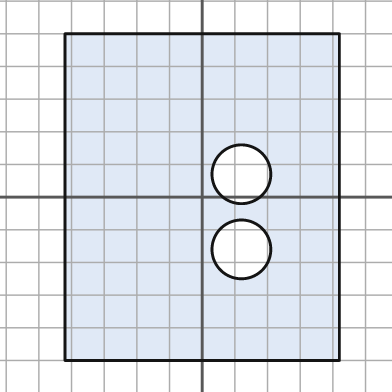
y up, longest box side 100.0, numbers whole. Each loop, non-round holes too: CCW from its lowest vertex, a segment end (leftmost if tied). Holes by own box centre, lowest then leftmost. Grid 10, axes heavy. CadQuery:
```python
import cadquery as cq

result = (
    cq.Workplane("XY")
    .moveTo(-42.0, -50.0)
    .lineTo(42.0, -50.0)
    .lineTo(42.0, 50.0)
    .lineTo(-42.0, 50.0)
    .close()
    .moveTo(12.0, -16.0)
    .circle(9.0)
    .moveTo(12.0, 7.0)
    .circle(9.0)
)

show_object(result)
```